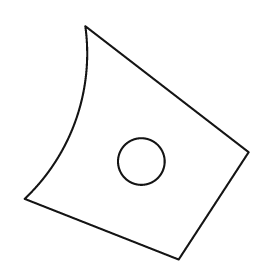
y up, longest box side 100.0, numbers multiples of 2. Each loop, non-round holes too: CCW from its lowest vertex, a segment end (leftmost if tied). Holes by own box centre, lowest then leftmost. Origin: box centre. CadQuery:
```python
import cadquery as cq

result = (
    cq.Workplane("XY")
    .moveTo(18.0, -50.0)
    .lineTo(48.0, -4.0)
    .lineTo(-22.0, 50.0)
    .threePointArc((-26.0, 10.0), (-48.0, -24.0))
    .close()
    .moveTo(2.0, -8.0)
    .circle(10.0)
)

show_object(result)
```